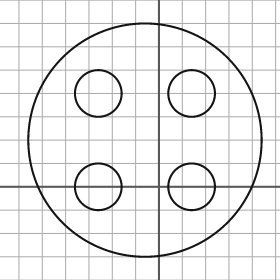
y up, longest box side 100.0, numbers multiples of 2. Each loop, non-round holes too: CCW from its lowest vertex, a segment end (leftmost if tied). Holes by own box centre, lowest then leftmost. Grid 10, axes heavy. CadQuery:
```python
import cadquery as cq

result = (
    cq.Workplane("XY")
    .moveTo(-6.0, 20.0)
    .circle(50.0)
    .moveTo(-26.0, 0.0)
    .circle(10.0)
    .moveTo(14.0, 0.0)
    .circle(10.0)
    .moveTo(-26.0, 40.0)
    .circle(10.0)
    .moveTo(14.0, 40.0)
    .circle(10.0)
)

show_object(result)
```